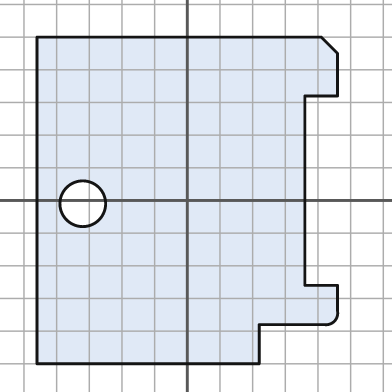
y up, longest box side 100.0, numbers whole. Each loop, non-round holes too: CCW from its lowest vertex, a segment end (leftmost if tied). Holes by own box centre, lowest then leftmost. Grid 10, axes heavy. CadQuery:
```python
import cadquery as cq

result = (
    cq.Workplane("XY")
    .moveTo(-46.0, -50.0)
    .lineTo(22.0, -50.0)
    .lineTo(22.0, -38.0)
    .lineTo(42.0, -38.0)
    .threePointArc((45.0, -37.0), (46.0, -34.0))
    .lineTo(46.0, -26.0)
    .lineTo(36.0, -26.0)
    .lineTo(36.0, 32.0)
    .lineTo(46.0, 32.0)
    .lineTo(46.0, 45.0)
    .lineTo(41.0, 50.0)
    .lineTo(-46.0, 50.0)
    .close()
    .moveTo(-32.0, -1.0)
    .circle(7.0)
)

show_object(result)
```